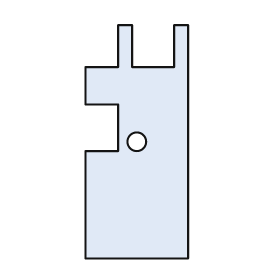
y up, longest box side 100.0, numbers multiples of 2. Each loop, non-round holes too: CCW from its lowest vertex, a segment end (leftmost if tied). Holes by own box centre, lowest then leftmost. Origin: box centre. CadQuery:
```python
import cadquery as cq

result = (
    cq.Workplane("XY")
    .moveTo(-22.0, -50.0)
    .lineTo(22.0, -50.0)
    .lineTo(22.0, 50.0)
    .lineTo(16.0, 50.0)
    .lineTo(16.0, 32.0)
    .lineTo(-2.0, 32.0)
    .lineTo(-2.0, 50.0)
    .lineTo(-8.0, 50.0)
    .lineTo(-8.0, 32.0)
    .lineTo(-22.0, 32.0)
    .lineTo(-22.0, 16.0)
    .lineTo(-8.0, 16.0)
    .lineTo(-8.0, -4.0)
    .lineTo(-22.0, -4.0)
    .close()
    .moveTo(0.0, 0.0)
    .circle(4.0)
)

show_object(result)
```